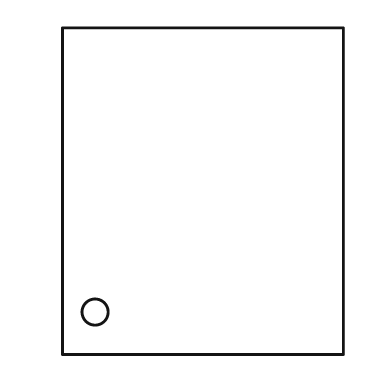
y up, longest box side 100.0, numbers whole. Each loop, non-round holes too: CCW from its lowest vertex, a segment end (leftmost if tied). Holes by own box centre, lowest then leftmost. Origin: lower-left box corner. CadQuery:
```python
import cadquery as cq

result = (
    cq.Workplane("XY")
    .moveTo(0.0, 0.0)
    .lineTo(86.0, 0.0)
    .lineTo(86.0, 100.0)
    .lineTo(0.0, 100.0)
    .close()
    .moveTo(10.0, 13.0)
    .circle(4.0)
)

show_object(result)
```